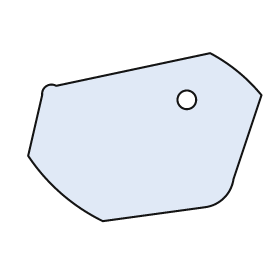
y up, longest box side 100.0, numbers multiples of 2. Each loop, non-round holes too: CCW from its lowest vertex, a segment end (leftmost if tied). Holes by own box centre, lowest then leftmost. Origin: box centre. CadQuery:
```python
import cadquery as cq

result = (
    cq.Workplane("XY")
    .moveTo(-18.0, -36.0)
    .lineTo(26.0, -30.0)
    .threePointArc((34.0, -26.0), (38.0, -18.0))
    .lineTo(50.0, 18.0)
    .threePointArc((40.0, 28.0), (28.0, 36.0))
    .lineTo(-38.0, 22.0)
    .threePointArc((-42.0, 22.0), (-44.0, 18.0))
    .lineTo(-50.0, -8.0)
    .threePointArc((-36.0, -24.0), (-18.0, -36.0))
    .close()
    .moveTo(18.0, 16.0)
    .circle(4.0)
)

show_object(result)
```